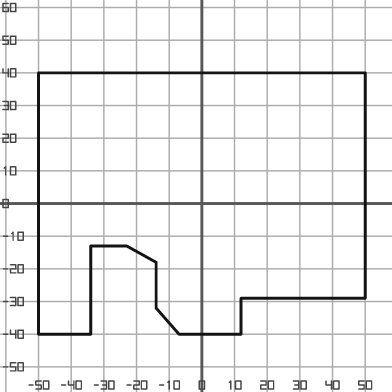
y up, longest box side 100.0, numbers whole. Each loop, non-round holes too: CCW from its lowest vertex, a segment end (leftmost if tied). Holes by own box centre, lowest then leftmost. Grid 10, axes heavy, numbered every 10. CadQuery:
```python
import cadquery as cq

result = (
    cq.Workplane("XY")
    .moveTo(-50.0, -40.0)
    .lineTo(-34.0, -40.0)
    .lineTo(-34.0, -13.0)
    .lineTo(-23.0, -13.0)
    .lineTo(-14.0, -18.0)
    .lineTo(-14.0, -32.0)
    .lineTo(-7.0, -40.0)
    .lineTo(12.0, -40.0)
    .lineTo(12.0, -29.0)
    .lineTo(50.0, -29.0)
    .lineTo(50.0, 40.0)
    .lineTo(-50.0, 40.0)
    .close()
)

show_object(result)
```